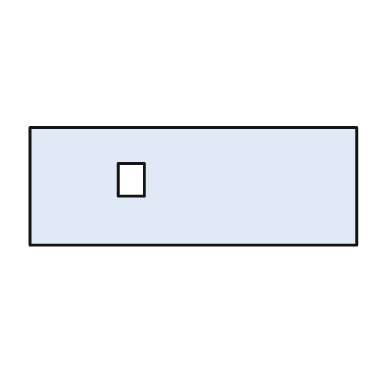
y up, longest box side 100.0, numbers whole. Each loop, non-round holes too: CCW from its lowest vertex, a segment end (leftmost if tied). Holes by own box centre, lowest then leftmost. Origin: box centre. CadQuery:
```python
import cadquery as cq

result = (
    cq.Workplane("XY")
    .moveTo(-50.0, -18.0)
    .lineTo(50.0, -18.0)
    .lineTo(50.0, 18.0)
    .lineTo(-50.0, 18.0)
    .close()
    .moveTo(-23.0, -3.0)
    .lineTo(-15.0, -3.0)
    .lineTo(-15.0, 7.0)
    .lineTo(-23.0, 7.0)
    .close()
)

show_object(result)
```